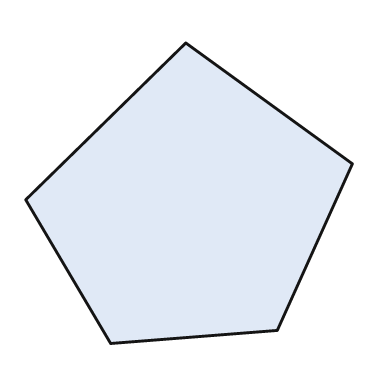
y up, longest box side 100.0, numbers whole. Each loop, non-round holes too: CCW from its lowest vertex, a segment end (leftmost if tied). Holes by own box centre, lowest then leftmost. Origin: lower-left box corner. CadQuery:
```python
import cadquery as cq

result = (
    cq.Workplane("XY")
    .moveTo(26.0, 0.0)
    .lineTo(77.0, 4.0)
    .lineTo(100.0, 55.0)
    .lineTo(49.0, 92.0)
    .lineTo(0.0, 44.0)
    .close()
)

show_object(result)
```